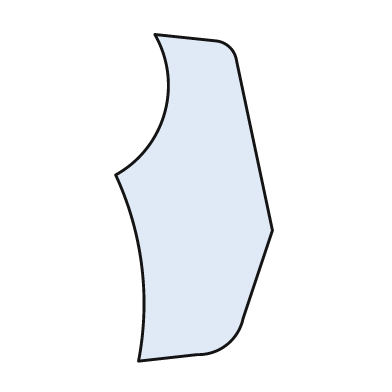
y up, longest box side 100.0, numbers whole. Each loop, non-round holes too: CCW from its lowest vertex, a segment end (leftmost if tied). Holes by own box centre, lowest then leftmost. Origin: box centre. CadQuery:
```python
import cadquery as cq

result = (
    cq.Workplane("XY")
    .moveTo(-17.0, -50.0)
    .lineTo(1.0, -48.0)
    .threePointArc((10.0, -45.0), (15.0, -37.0))
    .lineTo(24.0, -10.0)
    .lineTo(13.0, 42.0)
    .threePointArc((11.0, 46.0), (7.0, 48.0))
    .lineTo(-12.0, 50.0)
    .threePointArc((-9.0, 26.0), (-24.0, 7.0))
    .threePointArc((-16.0, -21.0), (-17.0, -50.0))
    .close()
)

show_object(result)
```